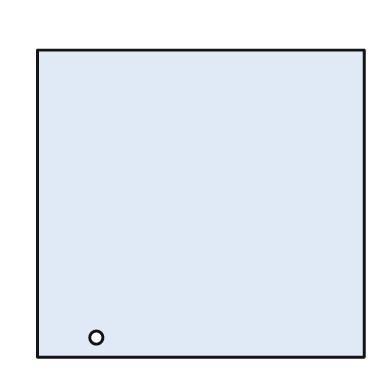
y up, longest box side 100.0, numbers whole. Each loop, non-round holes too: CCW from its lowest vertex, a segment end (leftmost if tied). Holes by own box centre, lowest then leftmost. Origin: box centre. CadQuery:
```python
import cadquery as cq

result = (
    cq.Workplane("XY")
    .moveTo(-50.0, -47.0)
    .lineTo(50.0, -47.0)
    .lineTo(50.0, 47.0)
    .lineTo(-50.0, 47.0)
    .close()
    .moveTo(-32.0, -41.0)
    .circle(2.0)
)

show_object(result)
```